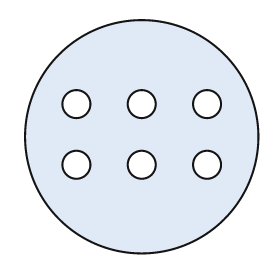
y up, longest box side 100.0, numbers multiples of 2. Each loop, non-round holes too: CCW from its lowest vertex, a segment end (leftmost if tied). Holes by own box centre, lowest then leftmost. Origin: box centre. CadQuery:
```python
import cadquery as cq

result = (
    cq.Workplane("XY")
    .moveTo(0.0, 0.0)
    .circle(50.0)
    .moveTo(-28.0, -12.0)
    .circle(6.0)
    .moveTo(0.0, -12.0)
    .circle(6.0)
    .moveTo(28.0, -12.0)
    .circle(6.0)
    .moveTo(-28.0, 14.0)
    .circle(6.0)
    .moveTo(0.0, 14.0)
    .circle(6.0)
    .moveTo(28.0, 14.0)
    .circle(6.0)
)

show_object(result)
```